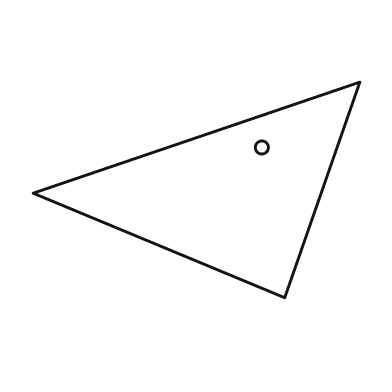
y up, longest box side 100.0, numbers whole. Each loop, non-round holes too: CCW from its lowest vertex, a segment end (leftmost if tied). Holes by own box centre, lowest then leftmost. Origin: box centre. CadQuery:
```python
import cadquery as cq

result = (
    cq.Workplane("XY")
    .moveTo(27.0, -33.0)
    .lineTo(50.0, 33.0)
    .lineTo(-50.0, -1.0)
    .close()
    .moveTo(20.0, 13.0)
    .circle(2.0)
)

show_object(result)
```